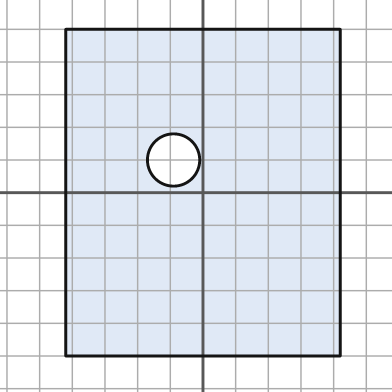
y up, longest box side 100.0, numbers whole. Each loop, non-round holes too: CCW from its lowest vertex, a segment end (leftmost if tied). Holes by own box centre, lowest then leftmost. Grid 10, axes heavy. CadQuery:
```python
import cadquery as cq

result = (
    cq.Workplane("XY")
    .moveTo(-42.0, -50.0)
    .lineTo(42.0, -50.0)
    .lineTo(42.0, 50.0)
    .lineTo(-42.0, 50.0)
    .close()
    .moveTo(-9.0, 10.0)
    .circle(8.0)
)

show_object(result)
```